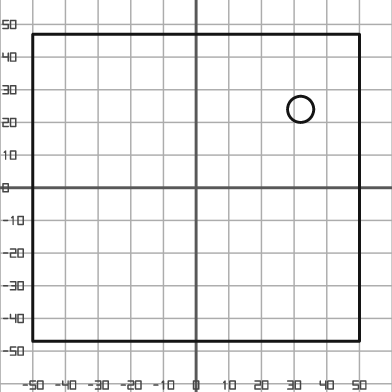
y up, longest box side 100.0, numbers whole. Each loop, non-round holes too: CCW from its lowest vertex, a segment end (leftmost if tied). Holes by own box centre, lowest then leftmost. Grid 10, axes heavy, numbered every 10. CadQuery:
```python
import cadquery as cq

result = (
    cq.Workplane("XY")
    .moveTo(-50.0, -47.0)
    .lineTo(50.0, -47.0)
    .lineTo(50.0, 47.0)
    .lineTo(-50.0, 47.0)
    .close()
    .moveTo(32.0, 24.0)
    .circle(4.0)
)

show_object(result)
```